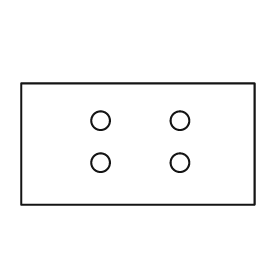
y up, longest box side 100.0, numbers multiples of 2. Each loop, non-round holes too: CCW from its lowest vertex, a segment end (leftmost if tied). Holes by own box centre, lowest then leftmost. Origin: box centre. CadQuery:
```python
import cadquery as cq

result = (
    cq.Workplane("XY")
    .moveTo(-50.0, -26.0)
    .lineTo(50.0, -26.0)
    .lineTo(50.0, 26.0)
    .lineTo(-50.0, 26.0)
    .close()
    .moveTo(-16.0, -8.0)
    .circle(4.0)
    .moveTo(18.0, -8.0)
    .circle(4.0)
    .moveTo(-16.0, 10.0)
    .circle(4.0)
    .moveTo(18.0, 10.0)
    .circle(4.0)
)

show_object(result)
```